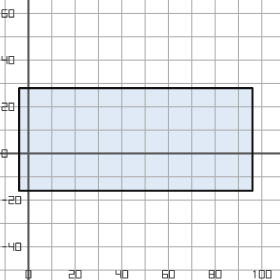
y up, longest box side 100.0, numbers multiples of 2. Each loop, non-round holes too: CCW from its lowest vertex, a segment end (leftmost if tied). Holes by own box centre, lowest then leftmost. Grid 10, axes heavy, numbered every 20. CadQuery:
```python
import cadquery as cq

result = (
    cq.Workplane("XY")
    .moveTo(-4.0, -16.0)
    .lineTo(96.0, -16.0)
    .lineTo(96.0, 28.0)
    .lineTo(-4.0, 28.0)
    .close()
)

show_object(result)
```